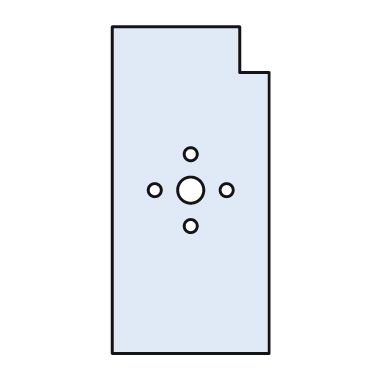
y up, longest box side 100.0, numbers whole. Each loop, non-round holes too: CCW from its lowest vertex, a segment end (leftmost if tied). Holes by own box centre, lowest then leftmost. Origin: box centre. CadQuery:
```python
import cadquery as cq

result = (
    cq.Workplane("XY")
    .moveTo(-24.0, -50.0)
    .lineTo(24.0, -50.0)
    .lineTo(24.0, 36.0)
    .lineTo(15.0, 36.0)
    .lineTo(15.0, 50.0)
    .lineTo(-24.0, 50.0)
    .close()
    .moveTo(0.0, -11.0)
    .circle(2.0)
    .moveTo(-11.0, 0.0)
    .circle(2.0)
    .moveTo(0.0, 0.0)
    .circle(4.0)
    .moveTo(11.0, 0.0)
    .circle(2.0)
    .moveTo(0.0, 11.0)
    .circle(2.0)
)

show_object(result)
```